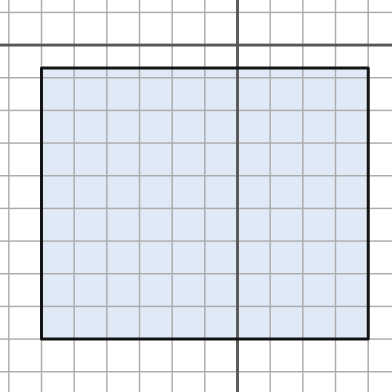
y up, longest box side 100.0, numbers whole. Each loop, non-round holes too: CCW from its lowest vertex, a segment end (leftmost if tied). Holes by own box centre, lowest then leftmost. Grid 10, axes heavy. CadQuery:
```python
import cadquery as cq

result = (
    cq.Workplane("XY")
    .moveTo(-60.0, -90.0)
    .lineTo(40.0, -90.0)
    .lineTo(40.0, -7.0)
    .lineTo(-60.0, -7.0)
    .close()
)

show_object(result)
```